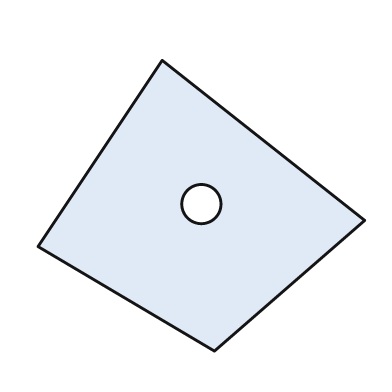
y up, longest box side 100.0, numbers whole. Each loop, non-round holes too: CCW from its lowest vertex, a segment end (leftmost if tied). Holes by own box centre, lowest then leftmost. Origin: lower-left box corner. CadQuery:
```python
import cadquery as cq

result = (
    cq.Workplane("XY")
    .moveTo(54.0, 0.0)
    .lineTo(100.0, 40.0)
    .lineTo(38.0, 89.0)
    .lineTo(0.0, 32.0)
    .close()
    .moveTo(50.0, 45.0)
    .circle(6.0)
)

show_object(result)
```